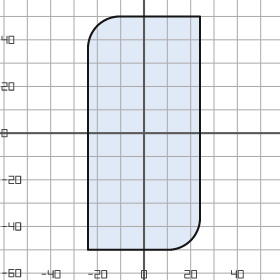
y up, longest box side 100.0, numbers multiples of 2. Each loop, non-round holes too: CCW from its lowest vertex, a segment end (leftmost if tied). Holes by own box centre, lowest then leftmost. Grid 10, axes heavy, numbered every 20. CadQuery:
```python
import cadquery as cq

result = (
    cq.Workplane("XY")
    .moveTo(-24.0, -50.0)
    .lineTo(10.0, -50.0)
    .threePointArc((20.0, -46.0), (24.0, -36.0))
    .lineTo(24.0, 50.0)
    .lineTo(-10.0, 50.0)
    .threePointArc((-20.0, 46.0), (-24.0, 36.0))
    .close()
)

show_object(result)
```